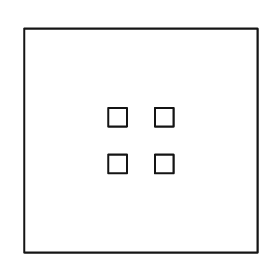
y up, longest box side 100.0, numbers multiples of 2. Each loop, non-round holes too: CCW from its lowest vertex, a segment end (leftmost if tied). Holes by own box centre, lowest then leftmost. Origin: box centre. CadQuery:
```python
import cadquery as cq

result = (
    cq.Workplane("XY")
    .moveTo(-50.0, -48.0)
    .lineTo(50.0, -48.0)
    .lineTo(50.0, 48.0)
    .lineTo(-50.0, 48.0)
    .close()
    .moveTo(-14.0, -14.0)
    .lineTo(-6.0, -14.0)
    .lineTo(-6.0, -6.0)
    .lineTo(-14.0, -6.0)
    .close()
    .moveTo(6.0, -14.0)
    .lineTo(14.0, -14.0)
    .lineTo(14.0, -6.0)
    .lineTo(6.0, -6.0)
    .close()
    .moveTo(-14.0, 6.0)
    .lineTo(-6.0, 6.0)
    .lineTo(-6.0, 14.0)
    .lineTo(-14.0, 14.0)
    .close()
    .moveTo(6.0, 6.0)
    .lineTo(14.0, 6.0)
    .lineTo(14.0, 14.0)
    .lineTo(6.0, 14.0)
    .close()
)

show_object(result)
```